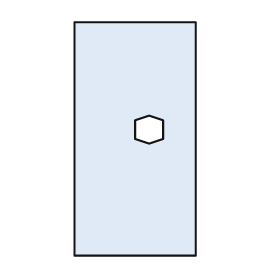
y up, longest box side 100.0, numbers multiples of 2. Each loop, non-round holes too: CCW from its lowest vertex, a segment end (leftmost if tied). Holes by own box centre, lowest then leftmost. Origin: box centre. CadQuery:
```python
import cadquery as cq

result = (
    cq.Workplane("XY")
    .moveTo(-26.0, -50.0)
    .lineTo(26.0, -50.0)
    .lineTo(26.0, 50.0)
    .lineTo(-26.0, 50.0)
    .close()
    .moveTo(6.0, -2.0)
    .lineTo(12.0, 0.0)
    .lineTo(12.0, 8.0)
    .lineTo(6.0, 10.0)
    .lineTo(0.0, 8.0)
    .lineTo(0.0, 0.0)
    .close()
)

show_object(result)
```